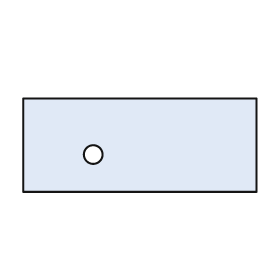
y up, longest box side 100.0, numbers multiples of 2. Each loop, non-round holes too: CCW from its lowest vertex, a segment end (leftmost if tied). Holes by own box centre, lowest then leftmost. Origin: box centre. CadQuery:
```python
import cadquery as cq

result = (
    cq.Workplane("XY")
    .moveTo(-50.0, -20.0)
    .lineTo(50.0, -20.0)
    .lineTo(50.0, 20.0)
    .lineTo(-50.0, 20.0)
    .close()
    .moveTo(-20.0, -4.0)
    .circle(4.0)
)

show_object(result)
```